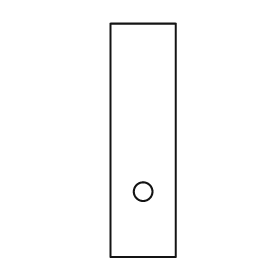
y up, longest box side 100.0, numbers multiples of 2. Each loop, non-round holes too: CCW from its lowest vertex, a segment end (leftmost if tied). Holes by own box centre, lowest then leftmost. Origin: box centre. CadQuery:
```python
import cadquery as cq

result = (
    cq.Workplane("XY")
    .moveTo(-14.0, -50.0)
    .lineTo(14.0, -50.0)
    .lineTo(14.0, 50.0)
    .lineTo(-14.0, 50.0)
    .close()
    .moveTo(0.0, -22.0)
    .circle(4.0)
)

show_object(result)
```